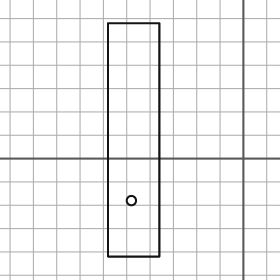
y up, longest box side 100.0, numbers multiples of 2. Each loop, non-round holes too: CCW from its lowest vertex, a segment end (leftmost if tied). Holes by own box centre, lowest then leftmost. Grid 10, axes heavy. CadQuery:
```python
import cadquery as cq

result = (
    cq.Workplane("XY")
    .moveTo(-58.0, -42.0)
    .lineTo(-36.0, -42.0)
    .lineTo(-36.0, 58.0)
    .lineTo(-58.0, 58.0)
    .close()
    .moveTo(-48.0, -18.0)
    .circle(2.0)
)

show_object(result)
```